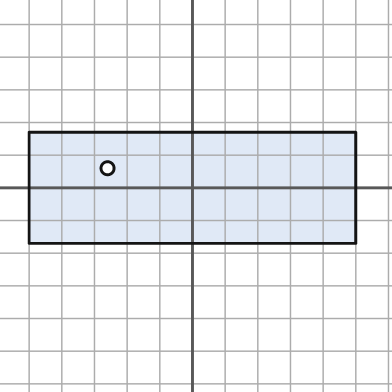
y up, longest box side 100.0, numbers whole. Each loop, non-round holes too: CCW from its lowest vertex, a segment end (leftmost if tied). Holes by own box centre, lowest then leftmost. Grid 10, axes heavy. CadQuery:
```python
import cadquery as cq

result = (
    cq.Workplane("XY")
    .moveTo(-50.0, -17.0)
    .lineTo(50.0, -17.0)
    .lineTo(50.0, 17.0)
    .lineTo(-50.0, 17.0)
    .close()
    .moveTo(-26.0, 6.0)
    .circle(2.0)
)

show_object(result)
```